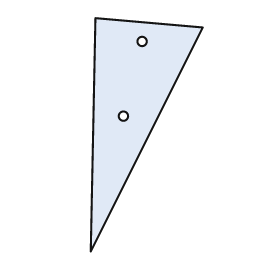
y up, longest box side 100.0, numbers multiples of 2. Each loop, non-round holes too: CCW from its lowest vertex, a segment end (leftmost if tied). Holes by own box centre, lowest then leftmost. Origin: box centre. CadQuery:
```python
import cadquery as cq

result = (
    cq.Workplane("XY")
    .moveTo(-24.0, -50.0)
    .lineTo(24.0, 46.0)
    .lineTo(-22.0, 50.0)
    .close()
    .moveTo(-10.0, 8.0)
    .circle(2.0)
    .moveTo(-2.0, 40.0)
    .circle(2.0)
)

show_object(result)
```